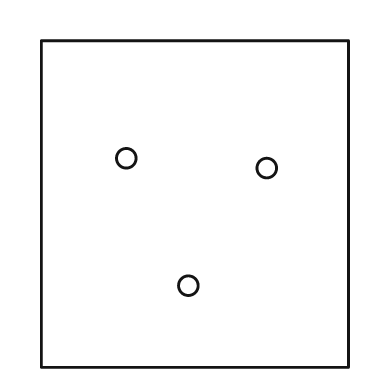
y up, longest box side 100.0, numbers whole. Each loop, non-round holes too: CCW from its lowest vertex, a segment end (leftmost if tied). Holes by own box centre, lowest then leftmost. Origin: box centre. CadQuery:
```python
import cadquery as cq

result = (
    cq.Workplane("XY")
    .moveTo(-47.0, -50.0)
    .lineTo(47.0, -50.0)
    .lineTo(47.0, 50.0)
    .lineTo(-47.0, 50.0)
    .close()
    .moveTo(-2.0, -25.0)
    .circle(3.0)
    .moveTo(22.0, 11.0)
    .circle(3.0)
    .moveTo(-21.0, 14.0)
    .circle(3.0)
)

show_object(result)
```